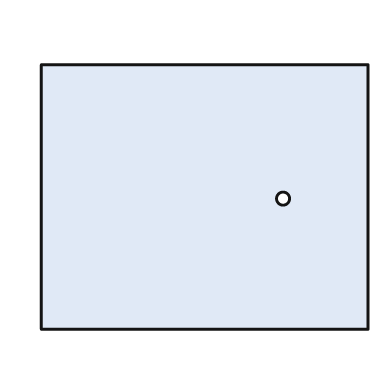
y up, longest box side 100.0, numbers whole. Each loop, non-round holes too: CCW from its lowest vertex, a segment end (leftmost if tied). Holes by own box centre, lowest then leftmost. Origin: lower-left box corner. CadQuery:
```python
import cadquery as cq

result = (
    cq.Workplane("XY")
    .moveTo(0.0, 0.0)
    .lineTo(100.0, 0.0)
    .lineTo(100.0, 81.0)
    .lineTo(0.0, 81.0)
    .close()
    .moveTo(74.0, 40.0)
    .circle(2.0)
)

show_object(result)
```